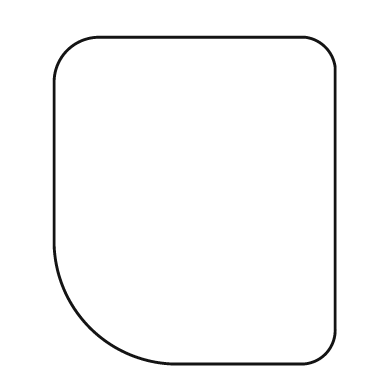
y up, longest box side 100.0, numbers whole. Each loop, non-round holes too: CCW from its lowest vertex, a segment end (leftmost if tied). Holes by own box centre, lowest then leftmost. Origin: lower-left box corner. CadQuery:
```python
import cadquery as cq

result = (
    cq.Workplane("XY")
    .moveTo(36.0, 0.0)
    .lineTo(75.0, 0.0)
    .threePointArc((83.0, 3.0), (86.0, 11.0))
    .lineTo(86.0, 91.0)
    .threePointArc((83.0, 97.0), (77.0, 100.0))
    .lineTo(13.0, 100.0)
    .threePointArc((4.0, 96.0), (0.0, 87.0))
    .lineTo(0.0, 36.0)
    .threePointArc((11.0, 11.0), (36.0, 0.0))
    .close()
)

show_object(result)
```